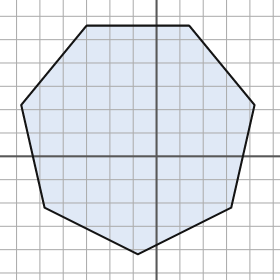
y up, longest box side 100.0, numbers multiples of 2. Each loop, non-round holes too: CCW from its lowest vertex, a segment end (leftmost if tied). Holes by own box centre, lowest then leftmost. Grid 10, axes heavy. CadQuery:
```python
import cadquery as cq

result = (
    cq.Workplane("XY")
    .moveTo(-8.0, -42.0)
    .lineTo(32.0, -22.0)
    .lineTo(42.0, 22.0)
    .lineTo(14.0, 56.0)
    .lineTo(-30.0, 56.0)
    .lineTo(-58.0, 22.0)
    .lineTo(-48.0, -22.0)
    .close()
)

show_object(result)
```